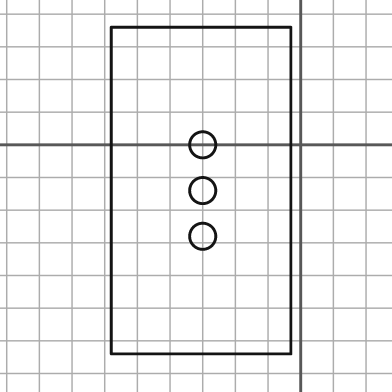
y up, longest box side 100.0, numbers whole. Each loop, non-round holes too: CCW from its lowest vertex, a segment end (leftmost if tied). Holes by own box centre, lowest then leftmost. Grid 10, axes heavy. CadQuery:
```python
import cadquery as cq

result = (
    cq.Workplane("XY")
    .moveTo(-58.0, -64.0)
    .lineTo(-3.0, -64.0)
    .lineTo(-3.0, 36.0)
    .lineTo(-58.0, 36.0)
    .close()
    .moveTo(-30.0, -28.0)
    .circle(4.0)
    .moveTo(-30.0, -14.0)
    .circle(4.0)
    .moveTo(-30.0, 0.0)
    .circle(4.0)
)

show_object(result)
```